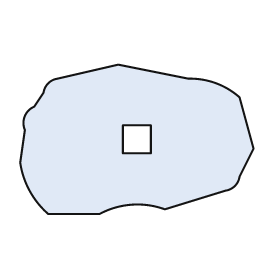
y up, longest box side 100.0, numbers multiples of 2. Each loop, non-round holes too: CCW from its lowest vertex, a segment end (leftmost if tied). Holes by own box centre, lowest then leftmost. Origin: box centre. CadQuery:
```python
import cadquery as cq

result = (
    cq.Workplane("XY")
    .moveTo(-38.0, -32.0)
    .lineTo(-16.0, -32.0)
    .threePointArc((-2.0, -28.0), (12.0, -30.0))
    .lineTo(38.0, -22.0)
    .threePointArc((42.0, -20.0), (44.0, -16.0))
    .lineTo(50.0, -4.0)
    .lineTo(44.0, 18.0)
    .threePointArc((34.0, 24.0), (22.0, 26.0))
    .lineTo(-8.0, 32.0)
    .lineTo(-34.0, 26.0)
    .threePointArc((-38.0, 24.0), (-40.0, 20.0))
    .lineTo(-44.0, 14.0)
    .threePointArc((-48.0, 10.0), (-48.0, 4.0))
    .lineTo(-50.0, -10.0)
    .threePointArc((-46.0, -22.0), (-38.0, -32.0))
    .close()
    .moveTo(-6.0, -6.0)
    .lineTo(6.0, -6.0)
    .lineTo(6.0, 6.0)
    .lineTo(-6.0, 6.0)
    .close()
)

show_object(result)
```